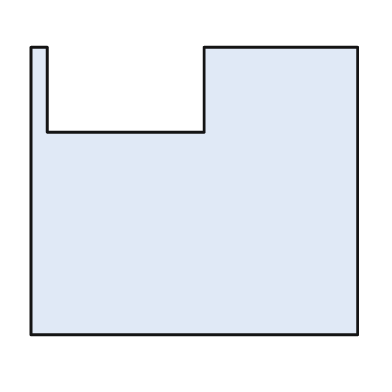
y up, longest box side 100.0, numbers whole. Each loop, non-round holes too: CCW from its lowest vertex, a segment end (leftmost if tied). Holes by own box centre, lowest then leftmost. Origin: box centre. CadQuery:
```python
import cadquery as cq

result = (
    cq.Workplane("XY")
    .moveTo(-50.0, -44.0)
    .lineTo(50.0, -44.0)
    .lineTo(50.0, 44.0)
    .lineTo(3.0, 44.0)
    .lineTo(3.0, 18.0)
    .lineTo(-45.0, 18.0)
    .lineTo(-45.0, 44.0)
    .lineTo(-50.0, 44.0)
    .close()
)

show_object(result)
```